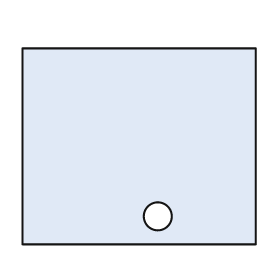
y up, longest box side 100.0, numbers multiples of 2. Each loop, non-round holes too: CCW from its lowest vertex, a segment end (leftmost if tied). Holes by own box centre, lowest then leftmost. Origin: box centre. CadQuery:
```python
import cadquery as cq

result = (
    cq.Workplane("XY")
    .moveTo(-50.0, -42.0)
    .lineTo(50.0, -42.0)
    .lineTo(50.0, 42.0)
    .lineTo(-50.0, 42.0)
    .close()
    .moveTo(8.0, -30.0)
    .circle(6.0)
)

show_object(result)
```